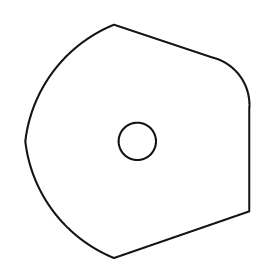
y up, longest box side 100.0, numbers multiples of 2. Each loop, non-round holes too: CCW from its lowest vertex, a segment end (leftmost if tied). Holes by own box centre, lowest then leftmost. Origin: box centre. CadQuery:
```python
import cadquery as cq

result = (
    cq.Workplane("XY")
    .moveTo(-10.0, -50.0)
    .lineTo(48.0, -30.0)
    .lineTo(48.0, 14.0)
    .threePointArc((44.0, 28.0), (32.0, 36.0))
    .lineTo(-10.0, 50.0)
    .threePointArc((-36.0, 30.0), (-48.0, 0.0))
    .threePointArc((-36.0, -30.0), (-10.0, -50.0))
    .close()
    .moveTo(0.0, 0.0)
    .circle(8.0)
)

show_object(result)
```